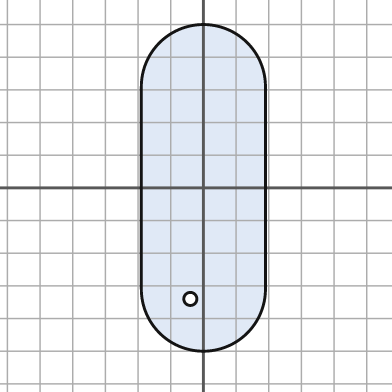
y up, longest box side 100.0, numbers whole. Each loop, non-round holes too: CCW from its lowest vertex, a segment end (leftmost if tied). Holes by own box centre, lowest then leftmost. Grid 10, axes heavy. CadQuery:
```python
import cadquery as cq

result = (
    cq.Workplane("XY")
    .moveTo(-19.0, -31.0)
    .threePointArc((0.0, -50.0), (19.0, -31.0))
    .lineTo(19.0, 31.0)
    .threePointArc((0.0, 50.0), (-19.0, 31.0))
    .close()
    .moveTo(-4.0, -34.0)
    .circle(2.0)
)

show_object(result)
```